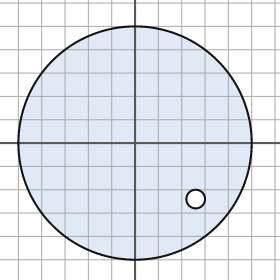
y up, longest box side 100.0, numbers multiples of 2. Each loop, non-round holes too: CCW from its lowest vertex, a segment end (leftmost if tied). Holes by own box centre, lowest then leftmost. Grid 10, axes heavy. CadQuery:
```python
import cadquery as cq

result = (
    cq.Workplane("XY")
    .moveTo(0.0, 0.0)
    .circle(50.0)
    .moveTo(26.0, -24.0)
    .circle(4.0)
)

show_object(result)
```